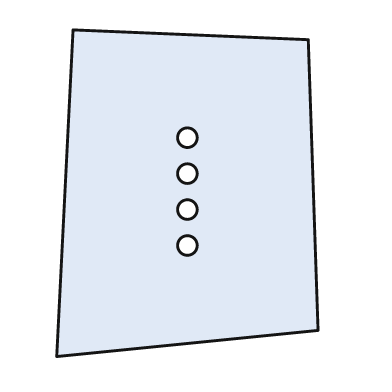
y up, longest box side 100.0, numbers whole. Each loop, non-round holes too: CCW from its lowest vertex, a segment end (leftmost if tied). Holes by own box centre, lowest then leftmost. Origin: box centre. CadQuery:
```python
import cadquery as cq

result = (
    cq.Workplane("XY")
    .moveTo(-40.0, -50.0)
    .lineTo(40.0, -42.0)
    .lineTo(37.0, 47.0)
    .lineTo(-35.0, 50.0)
    .close()
    .moveTo(0.0, -16.0)
    .circle(3.0)
    .moveTo(0.0, -5.0)
    .circle(3.0)
    .moveTo(0.0, 6.0)
    .circle(3.0)
    .moveTo(0.0, 17.0)
    .circle(3.0)
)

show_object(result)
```